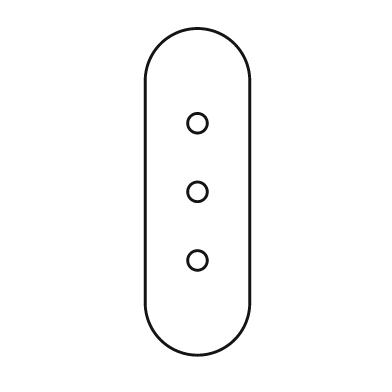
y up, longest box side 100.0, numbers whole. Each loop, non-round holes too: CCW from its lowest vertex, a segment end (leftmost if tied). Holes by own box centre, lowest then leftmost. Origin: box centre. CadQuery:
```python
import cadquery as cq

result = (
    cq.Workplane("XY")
    .moveTo(-16.0, -34.0)
    .threePointArc((0.0, -50.0), (16.0, -34.0))
    .lineTo(16.0, 34.0)
    .threePointArc((0.0, 50.0), (-16.0, 34.0))
    .close()
    .moveTo(0.0, -21.0)
    .circle(3.0)
    .moveTo(0.0, 0.0)
    .circle(3.0)
    .moveTo(0.0, 21.0)
    .circle(3.0)
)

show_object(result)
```